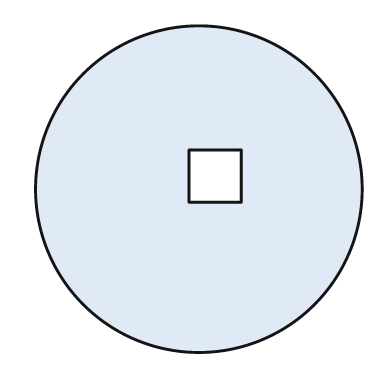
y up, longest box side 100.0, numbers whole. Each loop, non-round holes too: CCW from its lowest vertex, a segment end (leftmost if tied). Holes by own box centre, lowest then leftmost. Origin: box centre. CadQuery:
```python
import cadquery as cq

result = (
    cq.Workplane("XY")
    .moveTo(0.0, 0.0)
    .circle(50.0)
    .moveTo(-3.0, -4.0)
    .lineTo(13.0, -4.0)
    .lineTo(13.0, 12.0)
    .lineTo(-3.0, 12.0)
    .close()
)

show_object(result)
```